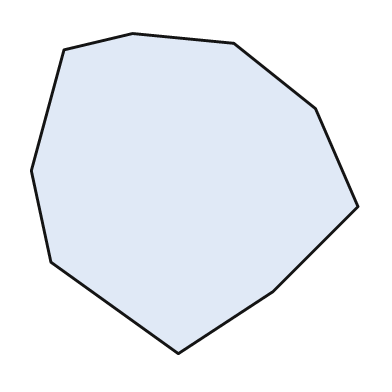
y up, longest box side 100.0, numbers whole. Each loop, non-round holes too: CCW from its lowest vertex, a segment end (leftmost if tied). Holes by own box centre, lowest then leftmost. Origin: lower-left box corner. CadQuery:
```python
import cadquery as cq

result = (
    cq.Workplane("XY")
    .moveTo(45.0, 0.0)
    .lineTo(74.0, 19.0)
    .lineTo(100.0, 45.0)
    .lineTo(87.0, 75.0)
    .lineTo(62.0, 95.0)
    .lineTo(31.0, 98.0)
    .lineTo(10.0, 93.0)
    .lineTo(0.0, 56.0)
    .lineTo(6.0, 28.0)
    .close()
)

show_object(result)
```